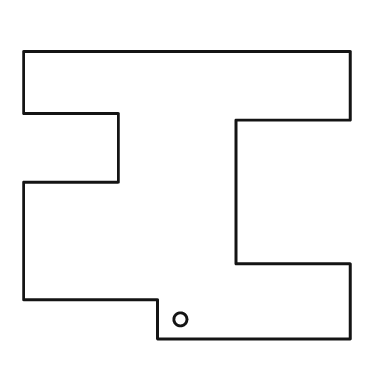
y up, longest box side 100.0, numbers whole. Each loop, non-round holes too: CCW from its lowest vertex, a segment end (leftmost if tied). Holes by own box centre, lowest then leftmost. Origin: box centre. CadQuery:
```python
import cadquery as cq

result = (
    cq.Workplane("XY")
    .moveTo(-9.0, -44.0)
    .lineTo(50.0, -44.0)
    .lineTo(50.0, -21.0)
    .lineTo(15.0, -21.0)
    .lineTo(15.0, 23.0)
    .lineTo(50.0, 23.0)
    .lineTo(50.0, 44.0)
    .lineTo(-50.0, 44.0)
    .lineTo(-50.0, 25.0)
    .lineTo(-21.0, 25.0)
    .lineTo(-21.0, 4.0)
    .lineTo(-50.0, 4.0)
    .lineTo(-50.0, -32.0)
    .lineTo(-9.0, -32.0)
    .close()
    .moveTo(-2.0, -38.0)
    .circle(2.0)
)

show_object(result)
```